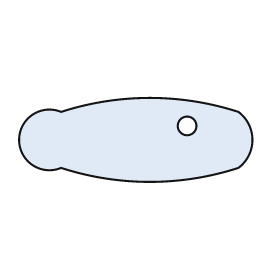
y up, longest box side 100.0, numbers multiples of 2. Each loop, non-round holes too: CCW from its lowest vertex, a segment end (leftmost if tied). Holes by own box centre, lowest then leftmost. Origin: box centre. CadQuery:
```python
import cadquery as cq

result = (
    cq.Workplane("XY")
    .moveTo(-32.0, -12.0)
    .threePointArc((6.0, -18.0), (44.0, -12.0))
    .threePointArc((50.0, 0.0), (44.0, 12.0))
    .threePointArc((6.0, 18.0), (-32.0, 12.0))
    .threePointArc((-50.0, 0.0), (-32.0, -12.0))
    .close()
    .moveTo(22.0, 6.0)
    .circle(4.0)
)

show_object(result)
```